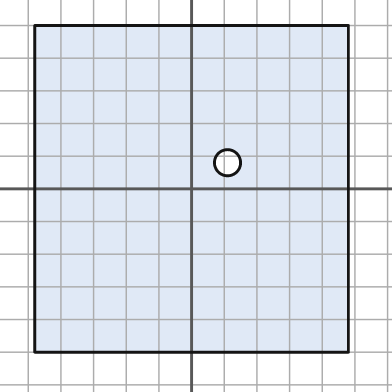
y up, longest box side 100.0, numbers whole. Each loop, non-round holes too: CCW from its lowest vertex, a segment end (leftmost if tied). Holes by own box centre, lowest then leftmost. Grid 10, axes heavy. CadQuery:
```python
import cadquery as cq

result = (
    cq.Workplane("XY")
    .moveTo(-48.0, -50.0)
    .lineTo(48.0, -50.0)
    .lineTo(48.0, 50.0)
    .lineTo(-48.0, 50.0)
    .close()
    .moveTo(11.0, 8.0)
    .circle(4.0)
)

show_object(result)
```